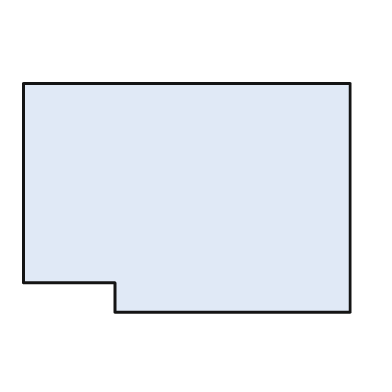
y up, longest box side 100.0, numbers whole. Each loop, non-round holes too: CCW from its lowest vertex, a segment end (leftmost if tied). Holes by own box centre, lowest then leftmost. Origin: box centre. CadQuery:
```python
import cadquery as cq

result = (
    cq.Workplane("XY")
    .moveTo(-22.0, -35.0)
    .lineTo(50.0, -35.0)
    .lineTo(50.0, 35.0)
    .lineTo(-50.0, 35.0)
    .lineTo(-50.0, -26.0)
    .lineTo(-22.0, -26.0)
    .close()
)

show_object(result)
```